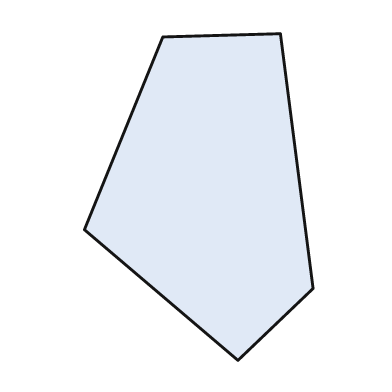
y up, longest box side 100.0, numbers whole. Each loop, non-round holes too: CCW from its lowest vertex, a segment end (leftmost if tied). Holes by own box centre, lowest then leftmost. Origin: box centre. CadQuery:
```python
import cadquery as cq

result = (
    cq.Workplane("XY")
    .moveTo(12.0, -50.0)
    .lineTo(35.0, -28.0)
    .lineTo(25.0, 50.0)
    .lineTo(-11.0, 49.0)
    .lineTo(-35.0, -10.0)
    .close()
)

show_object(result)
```